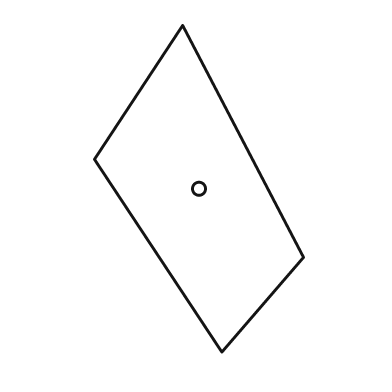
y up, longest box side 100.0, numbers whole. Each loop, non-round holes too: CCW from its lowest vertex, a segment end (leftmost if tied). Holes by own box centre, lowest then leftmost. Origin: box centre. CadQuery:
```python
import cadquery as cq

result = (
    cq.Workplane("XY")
    .moveTo(7.0, -50.0)
    .lineTo(32.0, -21.0)
    .lineTo(-5.0, 50.0)
    .lineTo(-32.0, 9.0)
    .close()
    .moveTo(0.0, 0.0)
    .circle(2.0)
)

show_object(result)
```